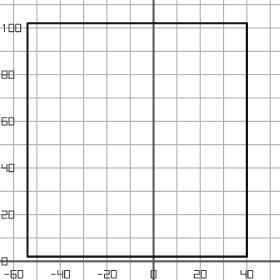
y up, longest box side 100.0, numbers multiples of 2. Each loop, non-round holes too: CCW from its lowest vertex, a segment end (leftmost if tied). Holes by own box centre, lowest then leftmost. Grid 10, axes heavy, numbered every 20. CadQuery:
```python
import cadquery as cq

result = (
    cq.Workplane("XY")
    .moveTo(-54.0, 2.0)
    .lineTo(40.0, 2.0)
    .lineTo(40.0, 102.0)
    .lineTo(-54.0, 102.0)
    .close()
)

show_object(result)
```